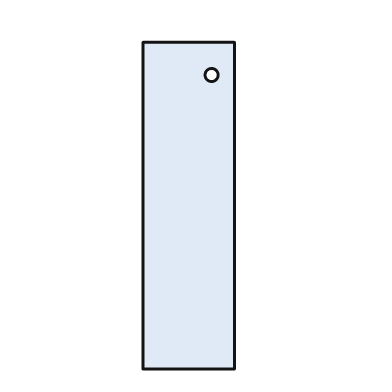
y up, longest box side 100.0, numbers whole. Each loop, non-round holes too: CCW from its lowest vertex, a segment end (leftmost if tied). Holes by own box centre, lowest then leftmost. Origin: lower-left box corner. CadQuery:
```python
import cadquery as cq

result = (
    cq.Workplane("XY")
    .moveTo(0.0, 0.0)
    .lineTo(28.0, 0.0)
    .lineTo(28.0, 100.0)
    .lineTo(0.0, 100.0)
    .close()
    .moveTo(21.0, 90.0)
    .circle(2.0)
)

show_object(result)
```